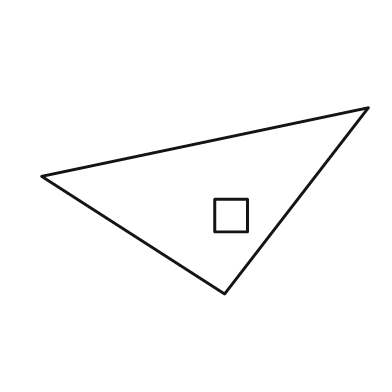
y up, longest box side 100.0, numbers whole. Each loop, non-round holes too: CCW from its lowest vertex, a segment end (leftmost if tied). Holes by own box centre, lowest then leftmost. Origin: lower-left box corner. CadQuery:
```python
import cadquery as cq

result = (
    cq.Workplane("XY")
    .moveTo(56.0, 0.0)
    .lineTo(100.0, 57.0)
    .lineTo(0.0, 36.0)
    .close()
    .moveTo(53.0, 19.0)
    .lineTo(63.0, 19.0)
    .lineTo(63.0, 29.0)
    .lineTo(53.0, 29.0)
    .close()
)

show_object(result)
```